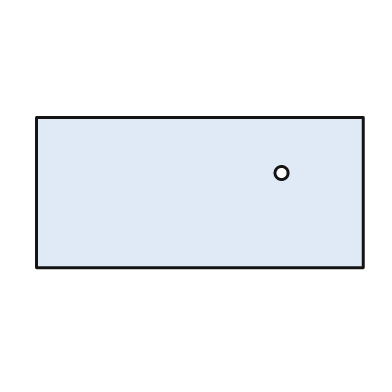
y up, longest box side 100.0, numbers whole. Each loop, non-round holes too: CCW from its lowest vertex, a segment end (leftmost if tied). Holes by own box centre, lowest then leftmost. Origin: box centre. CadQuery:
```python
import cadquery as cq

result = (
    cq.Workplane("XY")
    .moveTo(-50.0, -23.0)
    .lineTo(50.0, -23.0)
    .lineTo(50.0, 23.0)
    .lineTo(-50.0, 23.0)
    .close()
    .moveTo(25.0, 6.0)
    .circle(2.0)
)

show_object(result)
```